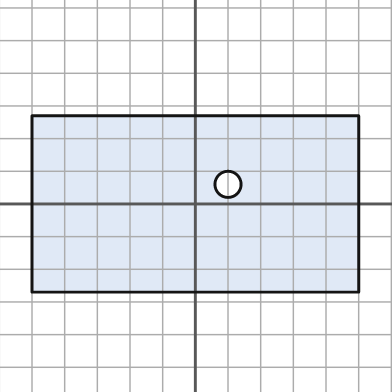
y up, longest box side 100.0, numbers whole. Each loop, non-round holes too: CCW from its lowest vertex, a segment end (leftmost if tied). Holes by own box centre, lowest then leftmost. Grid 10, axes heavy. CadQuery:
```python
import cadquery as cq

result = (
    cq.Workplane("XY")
    .moveTo(-50.0, -27.0)
    .lineTo(50.0, -27.0)
    .lineTo(50.0, 27.0)
    .lineTo(-50.0, 27.0)
    .close()
    .moveTo(10.0, 6.0)
    .circle(4.0)
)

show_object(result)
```